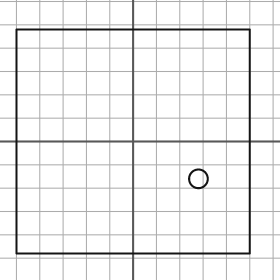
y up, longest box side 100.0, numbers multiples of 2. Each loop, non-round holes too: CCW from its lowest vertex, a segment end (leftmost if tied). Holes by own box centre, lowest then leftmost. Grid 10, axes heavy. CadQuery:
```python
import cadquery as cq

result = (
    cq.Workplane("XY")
    .moveTo(-50.0, -48.0)
    .lineTo(50.0, -48.0)
    .lineTo(50.0, 48.0)
    .lineTo(-50.0, 48.0)
    .close()
    .moveTo(28.0, -16.0)
    .circle(4.0)
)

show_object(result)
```